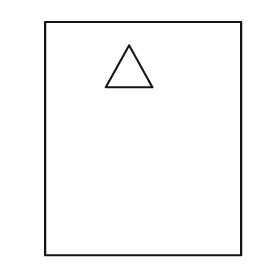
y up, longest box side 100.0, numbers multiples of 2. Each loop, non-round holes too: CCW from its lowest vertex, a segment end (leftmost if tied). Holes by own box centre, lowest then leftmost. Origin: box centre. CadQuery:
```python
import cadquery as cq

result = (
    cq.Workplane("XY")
    .moveTo(-42.0, -50.0)
    .lineTo(42.0, -50.0)
    .lineTo(42.0, 50.0)
    .lineTo(-42.0, 50.0)
    .close()
    .moveTo(-16.0, 22.0)
    .lineTo(4.0, 22.0)
    .lineTo(-6.0, 40.0)
    .close()
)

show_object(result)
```